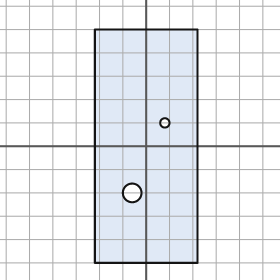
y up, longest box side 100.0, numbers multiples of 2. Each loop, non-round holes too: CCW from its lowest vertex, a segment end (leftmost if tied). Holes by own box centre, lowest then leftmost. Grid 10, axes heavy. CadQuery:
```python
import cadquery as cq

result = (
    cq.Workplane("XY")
    .moveTo(-22.0, -50.0)
    .lineTo(22.0, -50.0)
    .lineTo(22.0, 50.0)
    .lineTo(-22.0, 50.0)
    .close()
    .moveTo(-6.0, -20.0)
    .circle(4.0)
    .moveTo(8.0, 10.0)
    .circle(2.0)
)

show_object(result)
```